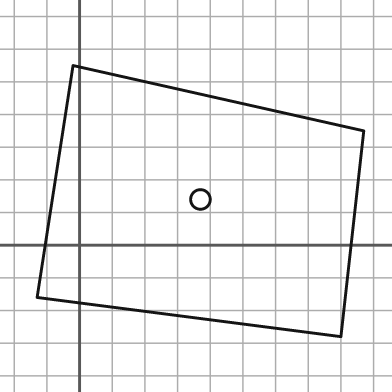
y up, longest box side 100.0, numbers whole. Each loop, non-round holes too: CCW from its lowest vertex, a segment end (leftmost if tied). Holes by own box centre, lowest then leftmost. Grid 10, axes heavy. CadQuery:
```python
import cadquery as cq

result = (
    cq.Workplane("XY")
    .moveTo(80.0, -28.0)
    .lineTo(87.0, 35.0)
    .lineTo(-2.0, 55.0)
    .lineTo(-13.0, -16.0)
    .close()
    .moveTo(37.0, 14.0)
    .circle(3.0)
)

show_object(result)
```